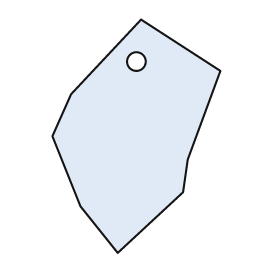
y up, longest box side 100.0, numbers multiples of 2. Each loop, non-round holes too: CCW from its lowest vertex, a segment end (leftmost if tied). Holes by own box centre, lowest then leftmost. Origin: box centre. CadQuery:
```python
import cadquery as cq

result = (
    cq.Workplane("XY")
    .moveTo(-8.0, -50.0)
    .lineTo(20.0, -24.0)
    .lineTo(22.0, -10.0)
    .lineTo(36.0, 28.0)
    .lineTo(2.0, 50.0)
    .lineTo(-28.0, 18.0)
    .lineTo(-36.0, 0.0)
    .lineTo(-24.0, -30.0)
    .close()
    .moveTo(0.0, 32.0)
    .circle(4.0)
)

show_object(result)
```